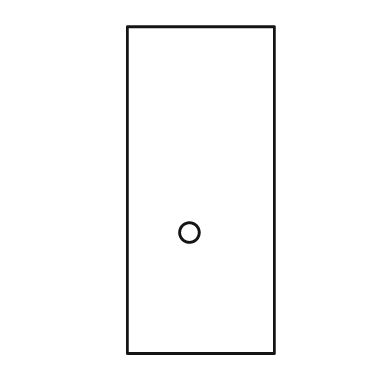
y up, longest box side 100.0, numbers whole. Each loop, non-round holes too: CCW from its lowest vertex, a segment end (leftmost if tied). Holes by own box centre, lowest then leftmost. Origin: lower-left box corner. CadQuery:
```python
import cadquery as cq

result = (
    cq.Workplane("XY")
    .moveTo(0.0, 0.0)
    .lineTo(45.0, 0.0)
    .lineTo(45.0, 100.0)
    .lineTo(0.0, 100.0)
    .close()
    .moveTo(19.0, 37.0)
    .circle(3.0)
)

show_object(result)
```